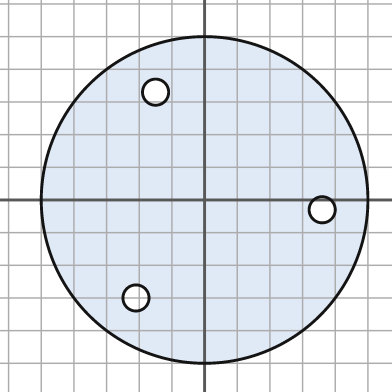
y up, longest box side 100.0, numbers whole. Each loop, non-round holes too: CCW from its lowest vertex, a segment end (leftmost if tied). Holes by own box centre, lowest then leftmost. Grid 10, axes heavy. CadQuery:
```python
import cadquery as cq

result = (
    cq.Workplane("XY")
    .moveTo(0.0, 0.0)
    .circle(50.0)
    .moveTo(-21.0, -30.0)
    .circle(4.0)
    .moveTo(36.0, -3.0)
    .circle(4.0)
    .moveTo(-15.0, 33.0)
    .circle(4.0)
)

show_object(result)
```